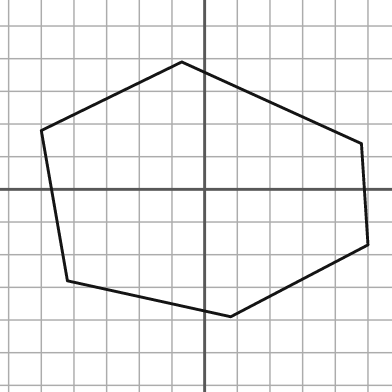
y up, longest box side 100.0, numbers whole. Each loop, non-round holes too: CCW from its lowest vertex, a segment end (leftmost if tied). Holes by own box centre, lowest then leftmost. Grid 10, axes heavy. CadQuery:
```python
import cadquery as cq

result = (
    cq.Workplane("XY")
    .moveTo(8.0, -39.0)
    .lineTo(50.0, -17.0)
    .lineTo(48.0, 14.0)
    .lineTo(-7.0, 39.0)
    .lineTo(-50.0, 18.0)
    .lineTo(-42.0, -28.0)
    .close()
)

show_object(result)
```